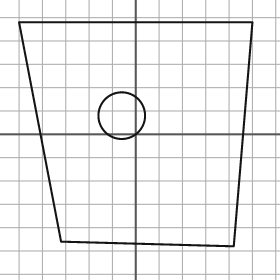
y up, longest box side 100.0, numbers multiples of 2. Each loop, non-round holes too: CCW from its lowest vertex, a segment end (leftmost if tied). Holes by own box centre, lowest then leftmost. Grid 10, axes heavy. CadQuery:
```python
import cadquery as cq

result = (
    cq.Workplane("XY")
    .moveTo(42.0, -48.0)
    .lineTo(50.0, 48.0)
    .lineTo(-50.0, 48.0)
    .lineTo(-32.0, -46.0)
    .close()
    .moveTo(-6.0, 8.0)
    .circle(10.0)
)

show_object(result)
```